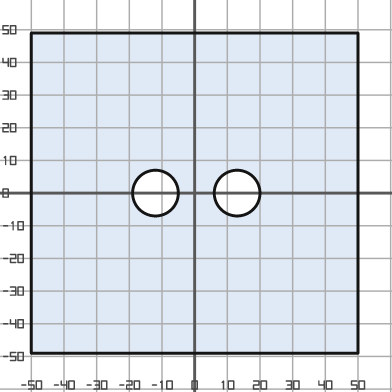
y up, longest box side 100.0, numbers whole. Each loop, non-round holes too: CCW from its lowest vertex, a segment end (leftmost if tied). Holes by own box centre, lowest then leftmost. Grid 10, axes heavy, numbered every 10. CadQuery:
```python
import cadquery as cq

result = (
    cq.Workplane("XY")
    .moveTo(-50.0, -49.0)
    .lineTo(50.0, -49.0)
    .lineTo(50.0, 49.0)
    .lineTo(-50.0, 49.0)
    .close()
    .moveTo(-12.0, 0.0)
    .circle(7.0)
    .moveTo(13.0, 0.0)
    .circle(7.0)
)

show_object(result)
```